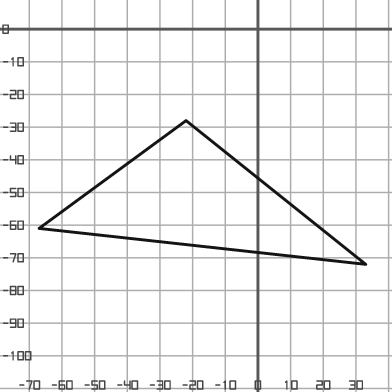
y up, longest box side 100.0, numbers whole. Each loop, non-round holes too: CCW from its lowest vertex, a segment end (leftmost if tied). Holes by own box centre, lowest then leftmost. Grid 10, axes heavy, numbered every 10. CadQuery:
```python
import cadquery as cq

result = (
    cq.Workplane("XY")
    .moveTo(33.0, -72.0)
    .lineTo(-22.0, -28.0)
    .lineTo(-67.0, -61.0)
    .close()
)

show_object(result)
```